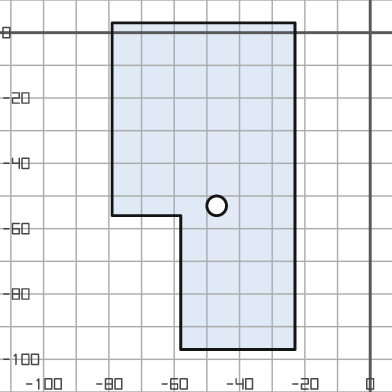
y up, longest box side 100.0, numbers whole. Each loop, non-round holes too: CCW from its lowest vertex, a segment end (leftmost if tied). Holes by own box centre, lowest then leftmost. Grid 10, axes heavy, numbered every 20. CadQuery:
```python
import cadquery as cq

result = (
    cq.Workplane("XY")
    .moveTo(-58.0, -97.0)
    .lineTo(-23.0, -97.0)
    .lineTo(-23.0, 3.0)
    .lineTo(-79.0, 3.0)
    .lineTo(-79.0, -56.0)
    .lineTo(-58.0, -56.0)
    .close()
    .moveTo(-47.0, -53.0)
    .circle(3.0)
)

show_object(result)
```